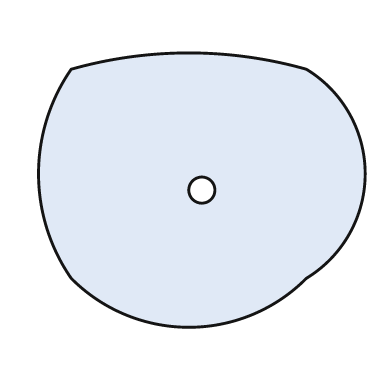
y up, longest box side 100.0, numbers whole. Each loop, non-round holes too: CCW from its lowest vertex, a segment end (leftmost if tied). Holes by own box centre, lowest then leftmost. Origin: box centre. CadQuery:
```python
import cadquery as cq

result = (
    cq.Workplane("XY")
    .moveTo(-40.0, -27.0)
    .threePointArc((-4.0, -42.0), (32.0, -27.0))
    .threePointArc((50.0, 5.0), (32.0, 37.0))
    .threePointArc((-4.0, 42.0), (-40.0, 37.0))
    .threePointArc((-50.0, 5.0), (-40.0, -27.0))
    .close()
    .moveTo(0.0, 0.0)
    .circle(4.0)
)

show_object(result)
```